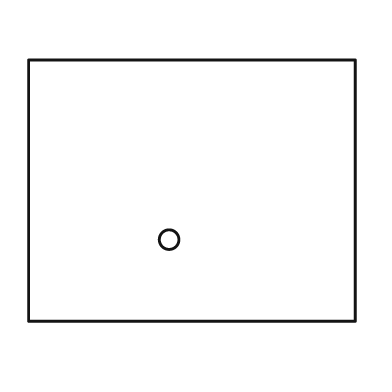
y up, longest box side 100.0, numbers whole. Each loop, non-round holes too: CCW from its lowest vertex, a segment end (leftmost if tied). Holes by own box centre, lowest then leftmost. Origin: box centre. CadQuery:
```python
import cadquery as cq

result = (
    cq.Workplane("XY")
    .moveTo(-50.0, -40.0)
    .lineTo(50.0, -40.0)
    .lineTo(50.0, 40.0)
    .lineTo(-50.0, 40.0)
    .close()
    .moveTo(-7.0, -15.0)
    .circle(3.0)
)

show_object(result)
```